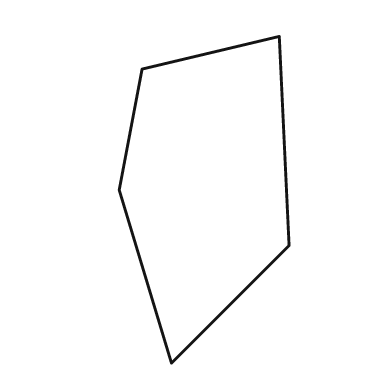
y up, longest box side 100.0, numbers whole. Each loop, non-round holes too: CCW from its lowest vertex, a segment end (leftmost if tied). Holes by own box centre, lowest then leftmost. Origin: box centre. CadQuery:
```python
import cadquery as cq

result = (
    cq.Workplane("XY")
    .moveTo(-10.0, -50.0)
    .lineTo(26.0, -14.0)
    .lineTo(23.0, 50.0)
    .lineTo(-19.0, 40.0)
    .lineTo(-26.0, 3.0)
    .close()
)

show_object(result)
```